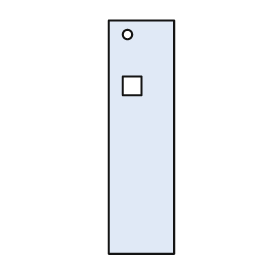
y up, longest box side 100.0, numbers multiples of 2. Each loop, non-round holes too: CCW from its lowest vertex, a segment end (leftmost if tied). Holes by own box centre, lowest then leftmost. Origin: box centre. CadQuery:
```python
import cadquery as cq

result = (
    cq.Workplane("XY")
    .moveTo(-14.0, -50.0)
    .lineTo(14.0, -50.0)
    .lineTo(14.0, 50.0)
    .lineTo(-14.0, 50.0)
    .close()
    .moveTo(-8.0, 18.0)
    .lineTo(0.0, 18.0)
    .lineTo(0.0, 26.0)
    .lineTo(-8.0, 26.0)
    .close()
    .moveTo(-6.0, 44.0)
    .circle(2.0)
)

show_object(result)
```